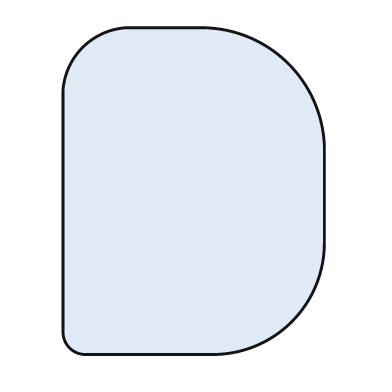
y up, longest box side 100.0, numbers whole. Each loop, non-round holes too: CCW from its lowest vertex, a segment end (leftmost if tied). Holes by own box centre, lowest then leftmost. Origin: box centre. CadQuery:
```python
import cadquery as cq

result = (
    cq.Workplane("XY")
    .moveTo(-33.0, -50.0)
    .lineTo(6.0, -50.0)
    .threePointArc((30.0, -40.0), (40.0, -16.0))
    .lineTo(40.0, 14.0)
    .threePointArc((29.0, 39.0), (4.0, 50.0))
    .lineTo(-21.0, 50.0)
    .threePointArc((-34.0, 44.0), (-40.0, 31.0))
    .lineTo(-40.0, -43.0)
    .threePointArc((-38.0, -48.0), (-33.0, -50.0))
    .close()
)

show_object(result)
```